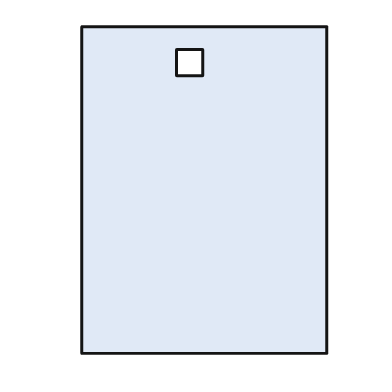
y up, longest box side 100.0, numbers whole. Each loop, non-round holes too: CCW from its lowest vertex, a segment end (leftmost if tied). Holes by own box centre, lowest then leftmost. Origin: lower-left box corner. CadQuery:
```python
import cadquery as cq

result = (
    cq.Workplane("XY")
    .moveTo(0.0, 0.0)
    .lineTo(75.0, 0.0)
    .lineTo(75.0, 100.0)
    .lineTo(0.0, 100.0)
    .close()
    .moveTo(29.0, 85.0)
    .lineTo(37.0, 85.0)
    .lineTo(37.0, 93.0)
    .lineTo(29.0, 93.0)
    .close()
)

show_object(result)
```